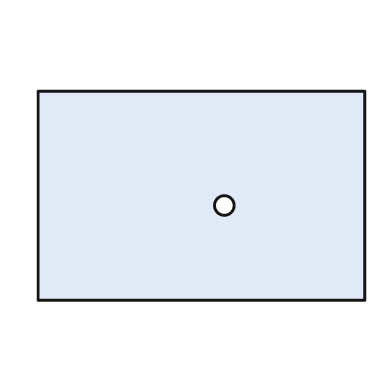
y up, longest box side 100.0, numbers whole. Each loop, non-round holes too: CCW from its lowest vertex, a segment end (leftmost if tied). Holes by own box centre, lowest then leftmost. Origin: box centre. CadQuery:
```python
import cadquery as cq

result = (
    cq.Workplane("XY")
    .moveTo(-50.0, -32.0)
    .lineTo(50.0, -32.0)
    .lineTo(50.0, 32.0)
    .lineTo(-50.0, 32.0)
    .close()
    .moveTo(7.0, -3.0)
    .circle(3.0)
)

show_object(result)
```